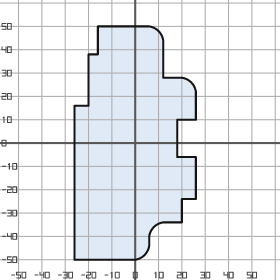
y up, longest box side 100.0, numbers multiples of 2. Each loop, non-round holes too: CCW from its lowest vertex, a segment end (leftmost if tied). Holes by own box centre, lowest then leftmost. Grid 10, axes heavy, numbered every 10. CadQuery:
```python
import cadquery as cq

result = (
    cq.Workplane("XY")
    .moveTo(-26.0, -50.0)
    .lineTo(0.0, -50.0)
    .threePointArc((4.0, -48.0), (6.0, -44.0))
    .lineTo(6.0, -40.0)
    .threePointArc((8.0, -36.0), (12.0, -34.0))
    .lineTo(20.0, -34.0)
    .lineTo(20.0, -24.0)
    .lineTo(26.0, -24.0)
    .lineTo(26.0, -6.0)
    .lineTo(18.0, -6.0)
    .lineTo(18.0, 10.0)
    .lineTo(26.0, 10.0)
    .lineTo(26.0, 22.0)
    .threePointArc((24.0, 26.0), (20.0, 28.0))
    .lineTo(12.0, 28.0)
    .lineTo(12.0, 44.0)
    .threePointArc((10.0, 48.0), (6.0, 50.0))
    .lineTo(-16.0, 50.0)
    .lineTo(-16.0, 38.0)
    .lineTo(-20.0, 38.0)
    .lineTo(-20.0, 16.0)
    .lineTo(-26.0, 16.0)
    .close()
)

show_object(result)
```